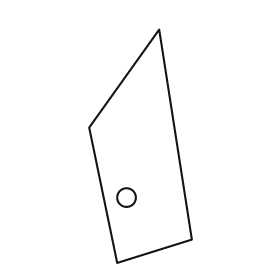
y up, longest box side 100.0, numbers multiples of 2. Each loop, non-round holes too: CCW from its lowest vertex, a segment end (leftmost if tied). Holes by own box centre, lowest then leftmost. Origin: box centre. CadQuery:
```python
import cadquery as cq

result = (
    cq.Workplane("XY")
    .moveTo(-10.0, -50.0)
    .lineTo(22.0, -40.0)
    .lineTo(8.0, 50.0)
    .lineTo(-22.0, 8.0)
    .close()
    .moveTo(-6.0, -22.0)
    .circle(4.0)
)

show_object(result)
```